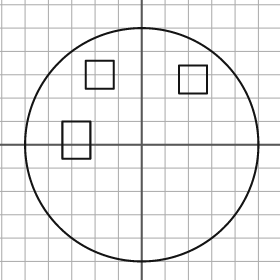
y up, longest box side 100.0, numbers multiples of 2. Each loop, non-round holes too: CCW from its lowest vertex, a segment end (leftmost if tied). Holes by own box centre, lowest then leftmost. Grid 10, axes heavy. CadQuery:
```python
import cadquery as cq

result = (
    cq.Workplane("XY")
    .moveTo(0.0, 0.0)
    .circle(50.0)
    .moveTo(-34.0, -6.0)
    .lineTo(-22.0, -6.0)
    .lineTo(-22.0, 10.0)
    .lineTo(-34.0, 10.0)
    .close()
    .moveTo(16.0, 22.0)
    .lineTo(28.0, 22.0)
    .lineTo(28.0, 34.0)
    .lineTo(16.0, 34.0)
    .close()
    .moveTo(-24.0, 24.0)
    .lineTo(-12.0, 24.0)
    .lineTo(-12.0, 36.0)
    .lineTo(-24.0, 36.0)
    .close()
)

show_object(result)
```